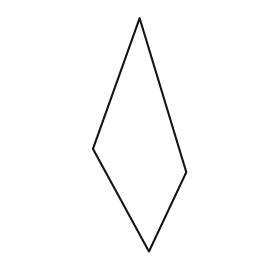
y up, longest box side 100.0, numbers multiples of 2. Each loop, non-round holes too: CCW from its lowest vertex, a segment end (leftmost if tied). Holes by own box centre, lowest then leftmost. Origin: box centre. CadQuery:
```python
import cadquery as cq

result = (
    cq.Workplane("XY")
    .moveTo(4.0, -50.0)
    .lineTo(20.0, -16.0)
    .lineTo(0.0, 50.0)
    .lineTo(-20.0, -6.0)
    .close()
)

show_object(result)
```